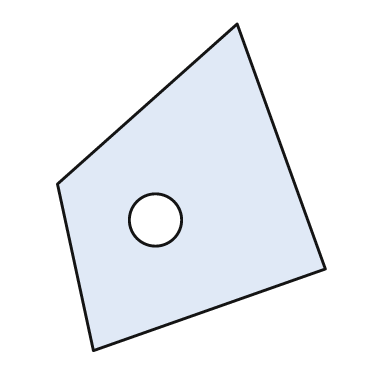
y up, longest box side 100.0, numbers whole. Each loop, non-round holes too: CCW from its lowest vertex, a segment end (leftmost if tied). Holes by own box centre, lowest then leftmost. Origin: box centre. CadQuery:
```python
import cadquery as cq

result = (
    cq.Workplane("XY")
    .moveTo(-30.0, -50.0)
    .lineTo(41.0, -25.0)
    .lineTo(14.0, 50.0)
    .lineTo(-41.0, 1.0)
    .close()
    .moveTo(-11.0, -10.0)
    .circle(8.0)
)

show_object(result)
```